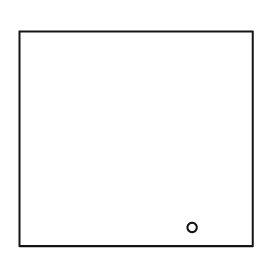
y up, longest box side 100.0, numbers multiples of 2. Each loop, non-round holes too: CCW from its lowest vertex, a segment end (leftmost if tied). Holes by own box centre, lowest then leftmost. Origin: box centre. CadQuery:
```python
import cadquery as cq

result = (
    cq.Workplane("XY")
    .moveTo(-50.0, -46.0)
    .lineTo(50.0, -46.0)
    .lineTo(50.0, 46.0)
    .lineTo(-50.0, 46.0)
    .close()
    .moveTo(24.0, -38.0)
    .circle(2.0)
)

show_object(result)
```